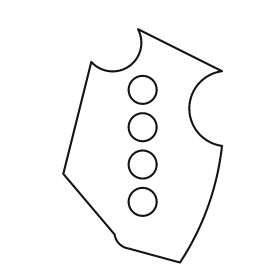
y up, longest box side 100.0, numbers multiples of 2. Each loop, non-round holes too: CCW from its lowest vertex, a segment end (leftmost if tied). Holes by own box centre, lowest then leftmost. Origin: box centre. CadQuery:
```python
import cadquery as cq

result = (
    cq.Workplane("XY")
    .moveTo(16.0, -50.0)
    .threePointArc((28.0, -26.0), (34.0, 0.0))
    .threePointArc((20.0, 16.0), (34.0, 32.0))
    .lineTo(-2.0, 50.0)
    .threePointArc((-6.0, 34.0), (-22.0, 36.0))
    .lineTo(-34.0, -12.0)
    .lineTo(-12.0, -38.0)
    .threePointArc((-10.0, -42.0), (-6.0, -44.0))
    .close()
    .moveTo(0.0, -24.0)
    .circle(6.0)
    .moveTo(0.0, -8.0)
    .circle(6.0)
    .moveTo(0.0, 8.0)
    .circle(6.0)
    .moveTo(0.0, 24.0)
    .circle(6.0)
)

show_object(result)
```